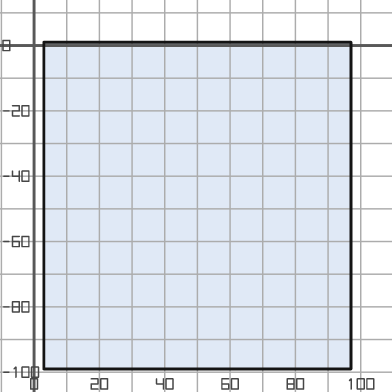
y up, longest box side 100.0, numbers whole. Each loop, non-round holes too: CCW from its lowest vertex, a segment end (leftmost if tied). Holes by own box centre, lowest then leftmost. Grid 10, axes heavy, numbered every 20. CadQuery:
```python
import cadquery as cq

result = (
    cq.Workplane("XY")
    .moveTo(3.0, -99.0)
    .lineTo(97.0, -99.0)
    .lineTo(97.0, 1.0)
    .lineTo(3.0, 1.0)
    .close()
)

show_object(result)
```